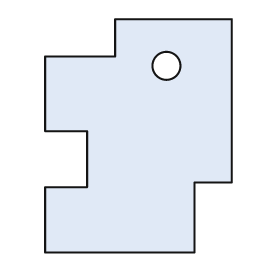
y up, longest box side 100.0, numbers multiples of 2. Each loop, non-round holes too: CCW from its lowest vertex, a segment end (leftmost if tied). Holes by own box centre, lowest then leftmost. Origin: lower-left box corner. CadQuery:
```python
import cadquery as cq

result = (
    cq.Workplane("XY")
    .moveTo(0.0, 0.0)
    .lineTo(64.0, 0.0)
    .lineTo(64.0, 30.0)
    .lineTo(80.0, 30.0)
    .lineTo(80.0, 100.0)
    .lineTo(30.0, 100.0)
    .lineTo(30.0, 84.0)
    .lineTo(0.0, 84.0)
    .lineTo(0.0, 52.0)
    .lineTo(18.0, 52.0)
    .lineTo(18.0, 28.0)
    .lineTo(0.0, 28.0)
    .close()
    .moveTo(52.0, 80.0)
    .circle(6.0)
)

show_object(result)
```